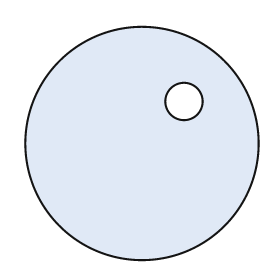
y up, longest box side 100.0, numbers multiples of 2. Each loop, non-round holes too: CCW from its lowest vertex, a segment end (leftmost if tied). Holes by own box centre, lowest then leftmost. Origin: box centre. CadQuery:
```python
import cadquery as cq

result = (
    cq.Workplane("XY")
    .moveTo(0.0, 0.0)
    .circle(50.0)
    .moveTo(18.0, 18.0)
    .circle(8.0)
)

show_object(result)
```